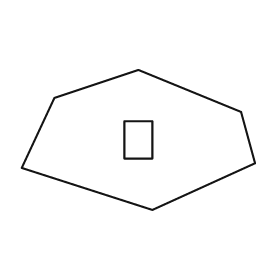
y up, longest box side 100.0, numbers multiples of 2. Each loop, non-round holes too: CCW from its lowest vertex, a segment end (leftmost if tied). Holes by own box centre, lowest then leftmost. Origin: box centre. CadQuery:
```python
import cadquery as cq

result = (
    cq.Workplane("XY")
    .moveTo(6.0, -30.0)
    .lineTo(50.0, -10.0)
    .lineTo(44.0, 12.0)
    .lineTo(0.0, 30.0)
    .lineTo(-36.0, 18.0)
    .lineTo(-50.0, -12.0)
    .close()
    .moveTo(-6.0, -8.0)
    .lineTo(6.0, -8.0)
    .lineTo(6.0, 8.0)
    .lineTo(-6.0, 8.0)
    .close()
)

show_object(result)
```